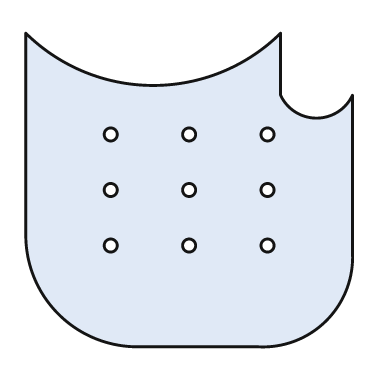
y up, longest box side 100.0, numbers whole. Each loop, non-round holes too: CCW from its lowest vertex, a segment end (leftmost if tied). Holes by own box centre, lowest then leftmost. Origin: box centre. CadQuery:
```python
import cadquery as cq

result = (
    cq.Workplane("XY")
    .moveTo(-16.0, -48.0)
    .lineTo(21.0, -48.0)
    .threePointArc((42.0, -40.0), (50.0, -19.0))
    .lineTo(50.0, 29.0)
    .threePointArc((39.0, 22.0), (28.0, 29.0))
    .lineTo(28.0, 48.0)
    .threePointArc((-11.0, 32.0), (-50.0, 48.0))
    .lineTo(-50.0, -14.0)
    .threePointArc((-40.0, -38.0), (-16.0, -48.0))
    .close()
    .moveTo(-24.0, -17.0)
    .circle(2.0)
    .moveTo(0.0, -17.0)
    .circle(2.0)
    .moveTo(24.0, -17.0)
    .circle(2.0)
    .moveTo(-24.0, 0.0)
    .circle(2.0)
    .moveTo(0.0, 0.0)
    .circle(2.0)
    .moveTo(24.0, 0.0)
    .circle(2.0)
    .moveTo(-24.0, 17.0)
    .circle(2.0)
    .moveTo(0.0, 17.0)
    .circle(2.0)
    .moveTo(24.0, 17.0)
    .circle(2.0)
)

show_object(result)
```